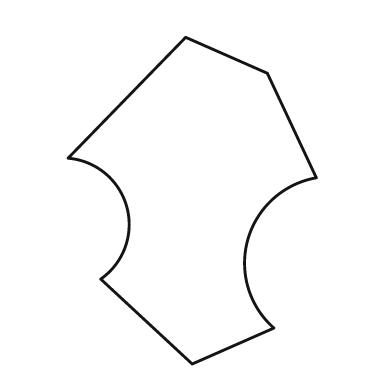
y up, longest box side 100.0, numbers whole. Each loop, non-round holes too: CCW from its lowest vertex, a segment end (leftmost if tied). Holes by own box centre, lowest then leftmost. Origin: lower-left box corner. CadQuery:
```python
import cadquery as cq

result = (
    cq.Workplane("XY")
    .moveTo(38.0, 0.0)
    .lineTo(63.0, 11.0)
    .threePointArc((55.0, 38.0), (76.0, 57.0))
    .lineTo(61.0, 89.0)
    .lineTo(36.0, 100.0)
    .lineTo(0.0, 63.0)
    .threePointArc((18.0, 48.0), (10.0, 26.0))
    .close()
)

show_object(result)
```